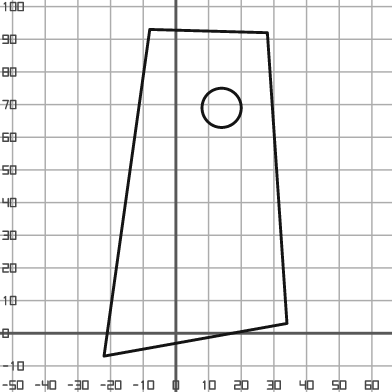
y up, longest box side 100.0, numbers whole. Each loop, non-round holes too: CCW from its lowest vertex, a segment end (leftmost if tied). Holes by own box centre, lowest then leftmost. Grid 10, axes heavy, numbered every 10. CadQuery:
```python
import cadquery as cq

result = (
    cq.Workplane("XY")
    .moveTo(-22.0, -7.0)
    .lineTo(34.0, 3.0)
    .lineTo(28.0, 92.0)
    .lineTo(-8.0, 93.0)
    .close()
    .moveTo(14.0, 69.0)
    .circle(6.0)
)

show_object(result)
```